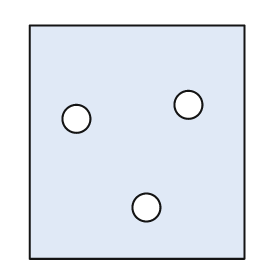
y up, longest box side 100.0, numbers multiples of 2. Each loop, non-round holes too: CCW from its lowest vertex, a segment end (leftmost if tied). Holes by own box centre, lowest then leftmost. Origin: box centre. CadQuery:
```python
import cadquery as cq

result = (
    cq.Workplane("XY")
    .moveTo(-46.0, -50.0)
    .lineTo(46.0, -50.0)
    .lineTo(46.0, 50.0)
    .lineTo(-46.0, 50.0)
    .close()
    .moveTo(4.0, -28.0)
    .circle(6.0)
    .moveTo(-26.0, 10.0)
    .circle(6.0)
    .moveTo(22.0, 16.0)
    .circle(6.0)
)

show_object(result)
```